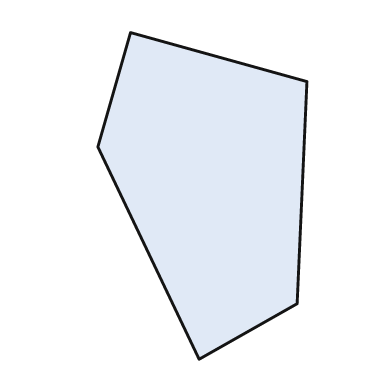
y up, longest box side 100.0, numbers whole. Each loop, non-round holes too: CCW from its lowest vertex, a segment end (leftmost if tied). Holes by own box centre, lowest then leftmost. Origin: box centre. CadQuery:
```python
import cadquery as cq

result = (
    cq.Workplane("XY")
    .moveTo(-1.0, -50.0)
    .lineTo(29.0, -33.0)
    .lineTo(32.0, 35.0)
    .lineTo(-22.0, 50.0)
    .lineTo(-32.0, 15.0)
    .close()
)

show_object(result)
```